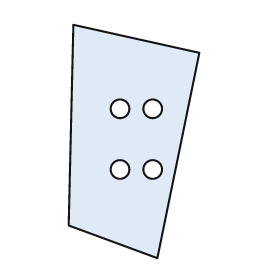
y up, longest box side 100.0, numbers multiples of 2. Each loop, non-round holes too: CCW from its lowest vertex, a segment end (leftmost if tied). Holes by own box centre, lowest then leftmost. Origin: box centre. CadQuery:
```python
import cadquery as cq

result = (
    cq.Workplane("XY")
    .moveTo(10.0, -50.0)
    .lineTo(28.0, 38.0)
    .lineTo(-26.0, 50.0)
    .lineTo(-28.0, -36.0)
    .close()
    .moveTo(-6.0, -12.0)
    .circle(4.0)
    .moveTo(8.0, -12.0)
    .circle(4.0)
    .moveTo(-6.0, 14.0)
    .circle(4.0)
    .moveTo(8.0, 14.0)
    .circle(4.0)
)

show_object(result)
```